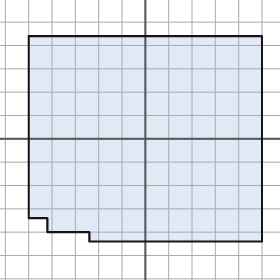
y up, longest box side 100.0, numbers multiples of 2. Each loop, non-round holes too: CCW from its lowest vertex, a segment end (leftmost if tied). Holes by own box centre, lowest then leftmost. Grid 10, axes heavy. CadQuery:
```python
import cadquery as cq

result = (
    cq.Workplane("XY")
    .moveTo(-24.0, -44.0)
    .lineTo(50.0, -44.0)
    .lineTo(50.0, 44.0)
    .lineTo(-50.0, 44.0)
    .lineTo(-50.0, -34.0)
    .lineTo(-42.0, -34.0)
    .lineTo(-42.0, -40.0)
    .lineTo(-24.0, -40.0)
    .close()
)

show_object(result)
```